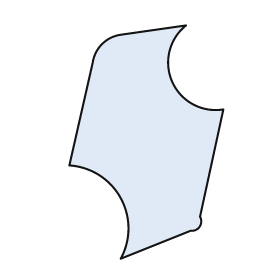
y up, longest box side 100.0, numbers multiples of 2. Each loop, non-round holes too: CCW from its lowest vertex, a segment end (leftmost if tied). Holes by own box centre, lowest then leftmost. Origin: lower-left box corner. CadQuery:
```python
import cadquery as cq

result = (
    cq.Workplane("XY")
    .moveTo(22.0, 0.0)
    .lineTo(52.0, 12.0)
    .threePointArc((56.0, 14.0), (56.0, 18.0))
    .lineTo(66.0, 64.0)
    .threePointArc((44.0, 76.0), (50.0, 100.0))
    .lineTo(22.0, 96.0)
    .threePointArc((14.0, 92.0), (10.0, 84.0))
    .lineTo(0.0, 40.0)
    .threePointArc((22.0, 26.0), (22.0, 0.0))
    .close()
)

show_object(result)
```